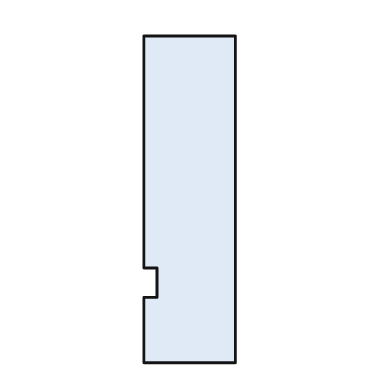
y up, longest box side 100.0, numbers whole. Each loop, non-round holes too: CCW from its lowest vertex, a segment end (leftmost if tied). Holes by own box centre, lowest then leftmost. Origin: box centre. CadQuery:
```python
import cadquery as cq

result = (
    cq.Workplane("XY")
    .moveTo(-14.0, -50.0)
    .lineTo(14.0, -50.0)
    .lineTo(14.0, 50.0)
    .lineTo(-14.0, 50.0)
    .lineTo(-14.0, -21.0)
    .lineTo(-10.0, -21.0)
    .lineTo(-10.0, -30.0)
    .lineTo(-14.0, -30.0)
    .close()
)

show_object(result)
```